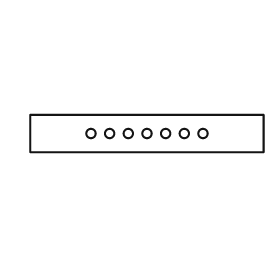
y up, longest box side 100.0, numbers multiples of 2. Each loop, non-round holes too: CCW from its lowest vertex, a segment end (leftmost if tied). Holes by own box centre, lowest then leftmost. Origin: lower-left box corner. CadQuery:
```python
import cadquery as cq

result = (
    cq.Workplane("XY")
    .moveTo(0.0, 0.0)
    .lineTo(100.0, 0.0)
    .lineTo(100.0, 16.0)
    .lineTo(0.0, 16.0)
    .close()
    .moveTo(26.0, 8.0)
    .circle(2.0)
    .moveTo(34.0, 8.0)
    .circle(2.0)
    .moveTo(42.0, 8.0)
    .circle(2.0)
    .moveTo(50.0, 8.0)
    .circle(2.0)
    .moveTo(58.0, 8.0)
    .circle(2.0)
    .moveTo(66.0, 8.0)
    .circle(2.0)
    .moveTo(74.0, 8.0)
    .circle(2.0)
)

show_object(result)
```